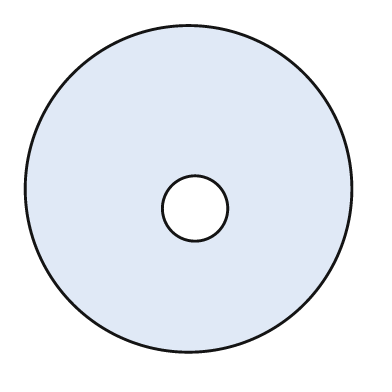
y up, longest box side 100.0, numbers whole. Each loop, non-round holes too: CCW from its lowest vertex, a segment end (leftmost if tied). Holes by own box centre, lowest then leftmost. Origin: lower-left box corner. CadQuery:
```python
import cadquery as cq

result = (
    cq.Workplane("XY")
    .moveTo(50.0, 50.0)
    .circle(50.0)
    .moveTo(52.0, 44.0)
    .circle(10.0)
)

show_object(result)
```